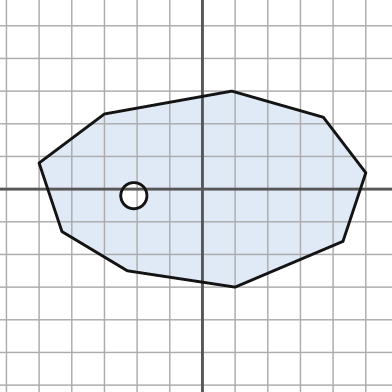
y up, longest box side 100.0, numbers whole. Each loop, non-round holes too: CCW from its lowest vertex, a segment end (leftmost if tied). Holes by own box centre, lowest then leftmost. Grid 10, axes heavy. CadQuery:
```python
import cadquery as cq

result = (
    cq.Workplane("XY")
    .moveTo(10.0, -30.0)
    .lineTo(43.0, -16.0)
    .lineTo(50.0, 5.0)
    .lineTo(37.0, 22.0)
    .lineTo(9.0, 30.0)
    .lineTo(-30.0, 23.0)
    .lineTo(-50.0, 8.0)
    .lineTo(-43.0, -13.0)
    .lineTo(-23.0, -25.0)
    .close()
    .moveTo(-21.0, -2.0)
    .circle(4.0)
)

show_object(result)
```